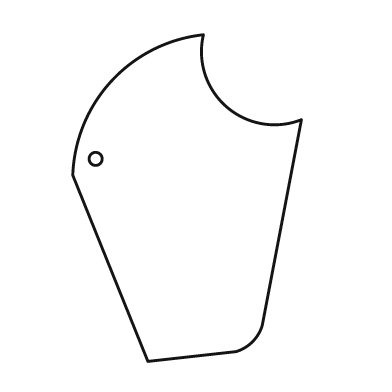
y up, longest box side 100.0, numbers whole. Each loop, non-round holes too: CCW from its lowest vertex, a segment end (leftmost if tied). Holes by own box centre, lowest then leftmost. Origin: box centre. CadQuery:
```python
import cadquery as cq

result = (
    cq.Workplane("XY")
    .moveTo(-12.0, -50.0)
    .lineTo(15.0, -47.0)
    .threePointArc((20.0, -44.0), (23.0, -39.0))
    .lineTo(35.0, 24.0)
    .threePointArc((12.0, 28.0), (5.0, 50.0))
    .threePointArc((-23.0, 36.0), (-35.0, 7.0))
    .close()
    .moveTo(-28.0, 12.0)
    .circle(2.0)
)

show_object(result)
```